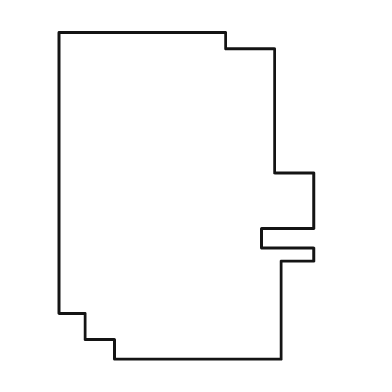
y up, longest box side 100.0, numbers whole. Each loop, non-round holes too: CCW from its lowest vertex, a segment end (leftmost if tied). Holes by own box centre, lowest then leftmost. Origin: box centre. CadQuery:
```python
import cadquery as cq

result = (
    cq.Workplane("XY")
    .moveTo(-22.0, -50.0)
    .lineTo(29.0, -50.0)
    .lineTo(29.0, -20.0)
    .lineTo(39.0, -20.0)
    .lineTo(39.0, -16.0)
    .lineTo(23.0, -16.0)
    .lineTo(23.0, -10.0)
    .lineTo(39.0, -10.0)
    .lineTo(39.0, 7.0)
    .lineTo(27.0, 7.0)
    .lineTo(27.0, 45.0)
    .lineTo(12.0, 45.0)
    .lineTo(12.0, 50.0)
    .lineTo(-39.0, 50.0)
    .lineTo(-39.0, -36.0)
    .lineTo(-31.0, -36.0)
    .lineTo(-31.0, -44.0)
    .lineTo(-22.0, -44.0)
    .close()
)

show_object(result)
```